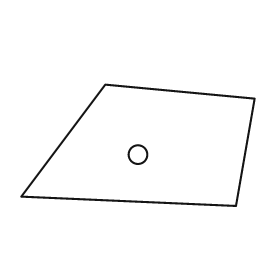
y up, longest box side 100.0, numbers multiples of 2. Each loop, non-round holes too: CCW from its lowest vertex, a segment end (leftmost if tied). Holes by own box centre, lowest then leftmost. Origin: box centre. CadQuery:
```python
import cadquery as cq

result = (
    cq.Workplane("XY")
    .moveTo(42.0, -26.0)
    .lineTo(50.0, 20.0)
    .lineTo(-14.0, 26.0)
    .lineTo(-50.0, -22.0)
    .close()
    .moveTo(0.0, -4.0)
    .circle(4.0)
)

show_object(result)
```